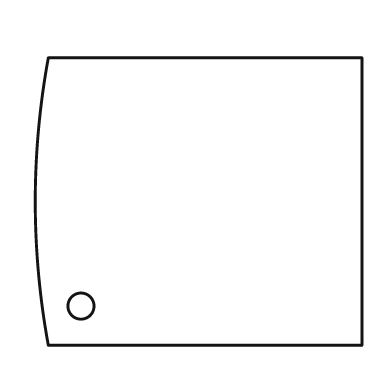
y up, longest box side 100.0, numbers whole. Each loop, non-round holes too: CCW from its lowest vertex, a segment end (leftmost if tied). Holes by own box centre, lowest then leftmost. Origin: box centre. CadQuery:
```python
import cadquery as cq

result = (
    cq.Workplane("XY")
    .moveTo(-46.0, -44.0)
    .lineTo(50.0, -44.0)
    .lineTo(50.0, 44.0)
    .lineTo(-46.0, 44.0)
    .threePointArc((-50.0, 0.0), (-46.0, -44.0))
    .close()
    .moveTo(-36.0, -32.0)
    .circle(4.0)
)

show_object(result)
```